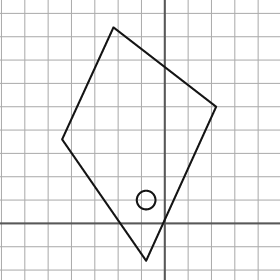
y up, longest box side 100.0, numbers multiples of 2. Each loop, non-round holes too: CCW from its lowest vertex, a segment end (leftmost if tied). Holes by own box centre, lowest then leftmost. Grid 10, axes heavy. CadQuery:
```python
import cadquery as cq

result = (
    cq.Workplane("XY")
    .moveTo(-8.0, -16.0)
    .lineTo(22.0, 50.0)
    .lineTo(-22.0, 84.0)
    .lineTo(-44.0, 36.0)
    .close()
    .moveTo(-8.0, 10.0)
    .circle(4.0)
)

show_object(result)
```